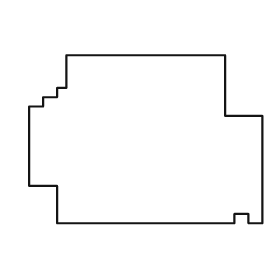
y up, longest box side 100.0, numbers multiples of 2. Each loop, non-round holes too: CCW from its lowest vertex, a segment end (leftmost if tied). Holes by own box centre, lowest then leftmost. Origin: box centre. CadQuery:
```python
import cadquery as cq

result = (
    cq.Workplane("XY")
    .moveTo(-38.0, -36.0)
    .lineTo(38.0, -36.0)
    .lineTo(38.0, -32.0)
    .lineTo(44.0, -32.0)
    .lineTo(44.0, -36.0)
    .lineTo(50.0, -36.0)
    .lineTo(50.0, 10.0)
    .lineTo(34.0, 10.0)
    .lineTo(34.0, 36.0)
    .lineTo(-34.0, 36.0)
    .lineTo(-34.0, 22.0)
    .lineTo(-38.0, 22.0)
    .lineTo(-38.0, 18.0)
    .lineTo(-44.0, 18.0)
    .lineTo(-44.0, 14.0)
    .lineTo(-50.0, 14.0)
    .lineTo(-50.0, -20.0)
    .lineTo(-38.0, -20.0)
    .close()
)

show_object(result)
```